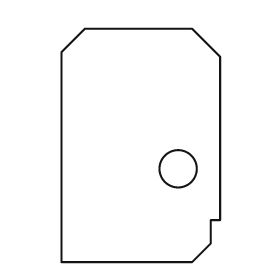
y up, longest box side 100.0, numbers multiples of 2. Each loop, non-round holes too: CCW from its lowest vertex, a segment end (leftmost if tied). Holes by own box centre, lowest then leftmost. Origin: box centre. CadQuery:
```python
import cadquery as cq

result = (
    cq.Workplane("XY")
    .moveTo(-34.0, -50.0)
    .lineTo(22.0, -50.0)
    .lineTo(30.0, -42.0)
    .lineTo(30.0, -32.0)
    .lineTo(34.0, -32.0)
    .lineTo(34.0, 38.0)
    .lineTo(22.0, 50.0)
    .lineTo(-24.0, 50.0)
    .lineTo(-34.0, 40.0)
    .close()
    .moveTo(16.0, -10.0)
    .circle(8.0)
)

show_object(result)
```